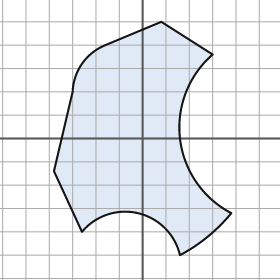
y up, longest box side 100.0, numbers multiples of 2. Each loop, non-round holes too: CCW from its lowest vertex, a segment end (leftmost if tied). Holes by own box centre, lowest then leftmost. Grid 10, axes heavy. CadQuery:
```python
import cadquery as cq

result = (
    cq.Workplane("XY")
    .moveTo(16.0, -50.0)
    .threePointArc((28.0, -42.0), (38.0, -32.0))
    .threePointArc((16.0, 0.0), (30.0, 36.0))
    .lineTo(8.0, 50.0)
    .lineTo(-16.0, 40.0)
    .threePointArc((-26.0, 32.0), (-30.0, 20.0))
    .lineTo(-38.0, -14.0)
    .lineTo(-26.0, -40.0)
    .threePointArc((-2.0, -32.0), (16.0, -50.0))
    .close()
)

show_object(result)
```